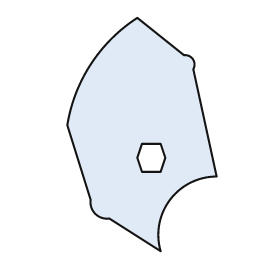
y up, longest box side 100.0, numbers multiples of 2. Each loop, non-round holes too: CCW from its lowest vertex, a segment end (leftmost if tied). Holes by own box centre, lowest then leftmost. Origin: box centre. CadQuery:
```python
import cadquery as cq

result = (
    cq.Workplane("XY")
    .moveTo(8.0, -50.0)
    .threePointArc((12.0, -28.0), (32.0, -18.0))
    .lineTo(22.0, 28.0)
    .threePointArc((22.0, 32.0), (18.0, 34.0))
    .lineTo(-2.0, 50.0)
    .threePointArc((-22.0, 30.0), (-32.0, 4.0))
    .lineTo(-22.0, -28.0)
    .threePointArc((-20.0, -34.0), (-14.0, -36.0))
    .close()
    .moveTo(0.0, -16.0)
    .lineTo(8.0, -16.0)
    .lineTo(10.0, -10.0)
    .lineTo(8.0, -4.0)
    .lineTo(0.0, -4.0)
    .lineTo(-2.0, -10.0)
    .close()
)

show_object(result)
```